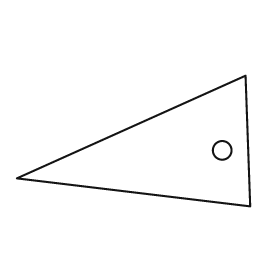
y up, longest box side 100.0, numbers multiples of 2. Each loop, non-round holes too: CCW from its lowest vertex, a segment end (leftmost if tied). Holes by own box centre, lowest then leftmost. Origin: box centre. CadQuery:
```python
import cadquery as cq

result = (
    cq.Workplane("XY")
    .moveTo(50.0, -28.0)
    .lineTo(48.0, 28.0)
    .lineTo(-50.0, -16.0)
    .close()
    .moveTo(38.0, -4.0)
    .circle(4.0)
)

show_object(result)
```